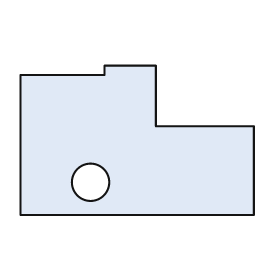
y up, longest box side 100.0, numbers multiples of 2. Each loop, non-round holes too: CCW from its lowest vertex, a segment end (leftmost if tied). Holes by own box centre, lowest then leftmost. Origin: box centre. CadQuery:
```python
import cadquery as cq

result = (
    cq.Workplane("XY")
    .moveTo(-50.0, -32.0)
    .lineTo(50.0, -32.0)
    .lineTo(50.0, 6.0)
    .lineTo(8.0, 6.0)
    .lineTo(8.0, 32.0)
    .lineTo(-14.0, 32.0)
    .lineTo(-14.0, 28.0)
    .lineTo(-50.0, 28.0)
    .close()
    .moveTo(-20.0, -18.0)
    .circle(8.0)
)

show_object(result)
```